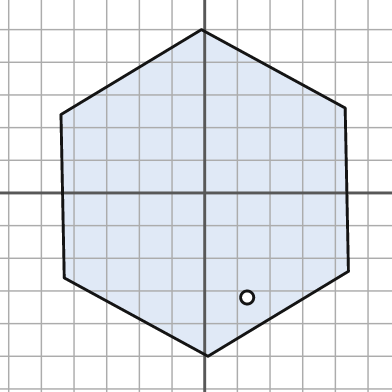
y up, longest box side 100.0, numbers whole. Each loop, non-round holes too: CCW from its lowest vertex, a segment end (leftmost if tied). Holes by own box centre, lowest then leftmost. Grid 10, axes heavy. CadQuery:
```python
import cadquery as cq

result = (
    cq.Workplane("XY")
    .moveTo(1.0, -50.0)
    .lineTo(44.0, -24.0)
    .lineTo(43.0, 26.0)
    .lineTo(-1.0, 50.0)
    .lineTo(-44.0, 24.0)
    .lineTo(-43.0, -26.0)
    .close()
    .moveTo(13.0, -32.0)
    .circle(2.0)
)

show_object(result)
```